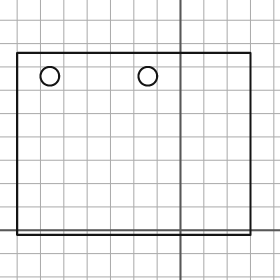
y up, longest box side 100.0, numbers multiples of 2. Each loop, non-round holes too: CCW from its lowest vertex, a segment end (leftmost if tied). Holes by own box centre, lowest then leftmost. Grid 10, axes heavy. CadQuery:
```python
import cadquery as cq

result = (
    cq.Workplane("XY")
    .moveTo(-70.0, -2.0)
    .lineTo(30.0, -2.0)
    .lineTo(30.0, 76.0)
    .lineTo(-70.0, 76.0)
    .close()
    .moveTo(-56.0, 66.0)
    .circle(4.0)
    .moveTo(-14.0, 66.0)
    .circle(4.0)
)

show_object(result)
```